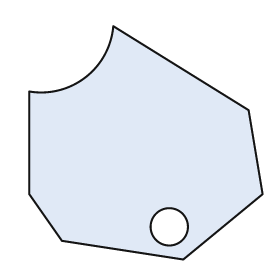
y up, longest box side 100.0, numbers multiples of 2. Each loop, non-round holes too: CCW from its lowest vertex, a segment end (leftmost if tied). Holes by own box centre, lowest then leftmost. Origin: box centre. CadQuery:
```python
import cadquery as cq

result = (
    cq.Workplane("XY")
    .moveTo(16.0, -50.0)
    .lineTo(50.0, -22.0)
    .lineTo(44.0, 14.0)
    .lineTo(-14.0, 50.0)
    .threePointArc((-26.0, 28.0), (-50.0, 22.0))
    .lineTo(-50.0, -22.0)
    .lineTo(-36.0, -42.0)
    .close()
    .moveTo(10.0, -36.0)
    .circle(8.0)
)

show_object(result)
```